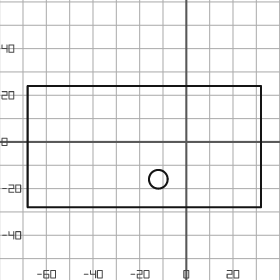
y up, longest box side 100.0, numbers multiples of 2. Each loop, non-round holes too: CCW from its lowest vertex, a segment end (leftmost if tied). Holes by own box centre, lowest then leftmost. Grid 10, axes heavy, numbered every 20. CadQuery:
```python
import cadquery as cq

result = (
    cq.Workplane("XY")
    .moveTo(-68.0, -28.0)
    .lineTo(32.0, -28.0)
    .lineTo(32.0, 24.0)
    .lineTo(-68.0, 24.0)
    .close()
    .moveTo(-12.0, -16.0)
    .circle(4.0)
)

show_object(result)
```